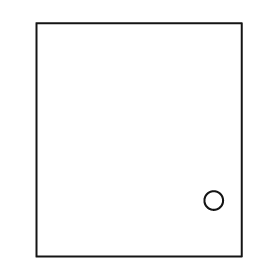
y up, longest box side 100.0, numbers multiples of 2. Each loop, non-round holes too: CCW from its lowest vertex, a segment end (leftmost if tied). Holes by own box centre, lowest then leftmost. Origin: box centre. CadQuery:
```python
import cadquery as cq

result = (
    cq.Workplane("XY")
    .moveTo(-44.0, -50.0)
    .lineTo(44.0, -50.0)
    .lineTo(44.0, 50.0)
    .lineTo(-44.0, 50.0)
    .close()
    .moveTo(32.0, -26.0)
    .circle(4.0)
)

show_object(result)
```